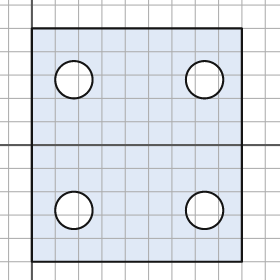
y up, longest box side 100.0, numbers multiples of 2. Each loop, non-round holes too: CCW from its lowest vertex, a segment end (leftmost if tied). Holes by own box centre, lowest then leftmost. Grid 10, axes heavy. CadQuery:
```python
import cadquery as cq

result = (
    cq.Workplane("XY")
    .moveTo(0.0, -50.0)
    .lineTo(90.0, -50.0)
    .lineTo(90.0, 50.0)
    .lineTo(0.0, 50.0)
    .close()
    .moveTo(18.0, -28.0)
    .circle(8.0)
    .moveTo(74.0, -28.0)
    .circle(8.0)
    .moveTo(18.0, 28.0)
    .circle(8.0)
    .moveTo(74.0, 28.0)
    .circle(8.0)
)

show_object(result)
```